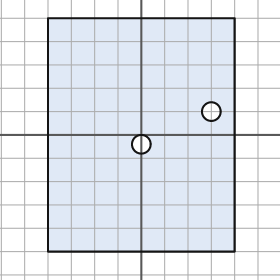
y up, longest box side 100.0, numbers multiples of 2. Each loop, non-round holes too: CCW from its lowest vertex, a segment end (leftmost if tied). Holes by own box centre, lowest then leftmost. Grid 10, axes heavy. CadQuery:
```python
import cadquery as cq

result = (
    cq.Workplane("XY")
    .moveTo(-40.0, -50.0)
    .lineTo(40.0, -50.0)
    .lineTo(40.0, 50.0)
    .lineTo(-40.0, 50.0)
    .close()
    .moveTo(0.0, -4.0)
    .circle(4.0)
    .moveTo(30.0, 10.0)
    .circle(4.0)
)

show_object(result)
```